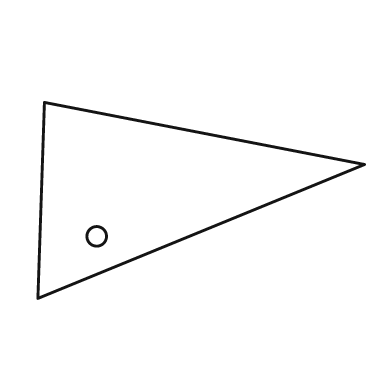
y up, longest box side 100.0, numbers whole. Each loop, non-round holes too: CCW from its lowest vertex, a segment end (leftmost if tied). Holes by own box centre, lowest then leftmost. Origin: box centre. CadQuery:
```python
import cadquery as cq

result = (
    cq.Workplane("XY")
    .moveTo(-50.0, -30.0)
    .lineTo(50.0, 11.0)
    .lineTo(-48.0, 30.0)
    .close()
    .moveTo(-32.0, -11.0)
    .circle(3.0)
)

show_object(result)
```